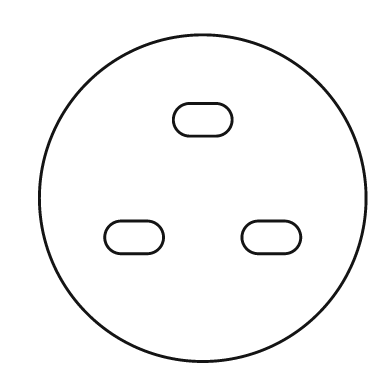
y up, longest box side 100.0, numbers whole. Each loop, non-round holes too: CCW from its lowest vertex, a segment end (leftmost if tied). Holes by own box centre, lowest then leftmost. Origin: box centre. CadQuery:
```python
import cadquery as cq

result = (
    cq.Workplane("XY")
    .moveTo(0.0, 0.0)
    .circle(50.0)
    .moveTo(-25.0, -17.0)
    .lineTo(-17.0, -17.0)
    .threePointArc((-12.0, -12.0), (-17.0, -7.0))
    .lineTo(-25.0, -7.0)
    .threePointArc((-30.0, -12.0), (-25.0, -17.0))
    .close()
    .moveTo(17.0, -17.0)
    .lineTo(25.0, -17.0)
    .threePointArc((30.0, -12.0), (25.0, -7.0))
    .lineTo(17.0, -7.0)
    .threePointArc((12.0, -12.0), (17.0, -17.0))
    .close()
    .moveTo(-4.0, 19.0)
    .lineTo(4.0, 19.0)
    .threePointArc((9.0, 24.0), (4.0, 29.0))
    .lineTo(-4.0, 29.0)
    .threePointArc((-9.0, 24.0), (-4.0, 19.0))
    .close()
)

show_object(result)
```